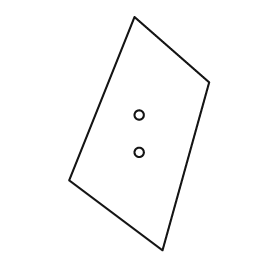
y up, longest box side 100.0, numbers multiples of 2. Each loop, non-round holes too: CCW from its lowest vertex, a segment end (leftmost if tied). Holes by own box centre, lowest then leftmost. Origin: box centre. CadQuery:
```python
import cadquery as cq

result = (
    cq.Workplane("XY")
    .moveTo(10.0, -50.0)
    .lineTo(30.0, 22.0)
    .lineTo(-2.0, 50.0)
    .lineTo(-30.0, -20.0)
    .close()
    .moveTo(0.0, -8.0)
    .circle(2.0)
    .moveTo(0.0, 8.0)
    .circle(2.0)
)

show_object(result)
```